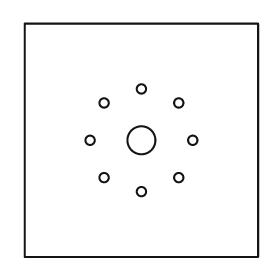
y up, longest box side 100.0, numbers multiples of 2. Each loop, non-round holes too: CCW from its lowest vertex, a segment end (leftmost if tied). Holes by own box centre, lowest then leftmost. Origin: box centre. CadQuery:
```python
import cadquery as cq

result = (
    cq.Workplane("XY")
    .moveTo(-50.0, -50.0)
    .lineTo(50.0, -50.0)
    .lineTo(50.0, 50.0)
    .lineTo(-50.0, 50.0)
    .close()
    .moveTo(0.0, -22.0)
    .circle(2.0)
    .moveTo(-16.0, -16.0)
    .circle(2.0)
    .moveTo(16.0, -16.0)
    .circle(2.0)
    .moveTo(-22.0, 0.0)
    .circle(2.0)
    .moveTo(0.0, 0.0)
    .circle(6.0)
    .moveTo(22.0, 0.0)
    .circle(2.0)
    .moveTo(-16.0, 16.0)
    .circle(2.0)
    .moveTo(16.0, 16.0)
    .circle(2.0)
    .moveTo(0.0, 22.0)
    .circle(2.0)
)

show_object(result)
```